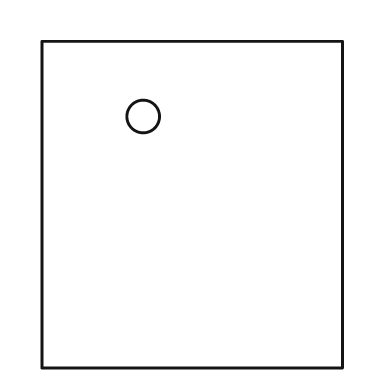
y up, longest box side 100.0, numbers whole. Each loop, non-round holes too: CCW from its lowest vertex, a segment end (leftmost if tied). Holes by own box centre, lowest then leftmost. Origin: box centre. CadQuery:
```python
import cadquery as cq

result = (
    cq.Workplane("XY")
    .moveTo(-46.0, -50.0)
    .lineTo(46.0, -50.0)
    .lineTo(46.0, 50.0)
    .lineTo(-46.0, 50.0)
    .close()
    .moveTo(-15.0, 27.0)
    .circle(5.0)
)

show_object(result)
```